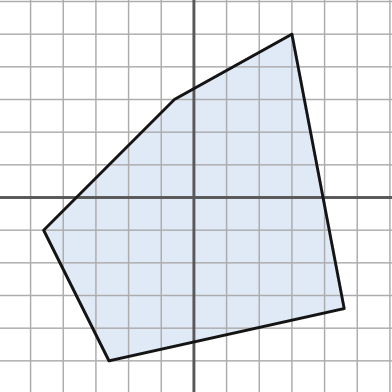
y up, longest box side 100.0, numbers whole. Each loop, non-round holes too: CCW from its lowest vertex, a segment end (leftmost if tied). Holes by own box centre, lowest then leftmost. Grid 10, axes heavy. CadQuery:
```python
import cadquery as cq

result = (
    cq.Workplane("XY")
    .moveTo(-26.0, -50.0)
    .lineTo(46.0, -34.0)
    .lineTo(30.0, 50.0)
    .lineTo(-6.0, 30.0)
    .lineTo(-46.0, -10.0)
    .close()
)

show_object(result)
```